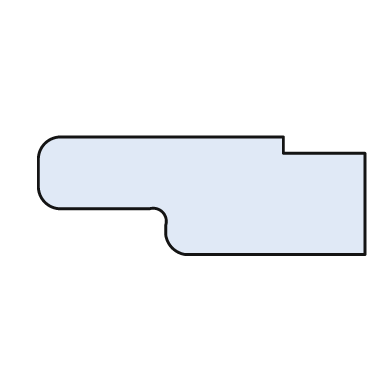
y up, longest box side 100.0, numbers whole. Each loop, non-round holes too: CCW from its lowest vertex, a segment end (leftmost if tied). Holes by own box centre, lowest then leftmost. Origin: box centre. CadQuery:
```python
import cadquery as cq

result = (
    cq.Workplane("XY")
    .moveTo(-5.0, -18.0)
    .lineTo(50.0, -18.0)
    .lineTo(50.0, 13.0)
    .lineTo(25.0, 13.0)
    .lineTo(25.0, 18.0)
    .lineTo(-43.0, 18.0)
    .threePointArc((-48.0, 16.0), (-50.0, 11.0))
    .lineTo(-50.0, 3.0)
    .threePointArc((-48.0, -2.0), (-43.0, -4.0))
    .lineTo(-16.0, -4.0)
    .threePointArc((-12.0, -5.0), (-11.0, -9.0))
    .lineTo(-11.0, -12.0)
    .threePointArc((-9.0, -16.0), (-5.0, -18.0))
    .close()
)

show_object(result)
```